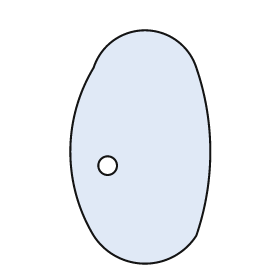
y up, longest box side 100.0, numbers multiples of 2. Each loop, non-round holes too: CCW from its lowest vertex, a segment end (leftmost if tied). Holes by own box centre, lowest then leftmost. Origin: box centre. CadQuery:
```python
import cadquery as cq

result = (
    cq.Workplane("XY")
    .moveTo(-20.0, -38.0)
    .threePointArc((2.0, -50.0), (24.0, -38.0))
    .threePointArc((30.0, -2.0), (24.0, 34.0))
    .threePointArc((2.0, 50.0), (-20.0, 34.0))
    .threePointArc((-30.0, -2.0), (-20.0, -38.0))
    .close()
    .moveTo(-14.0, -8.0)
    .circle(4.0)
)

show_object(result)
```